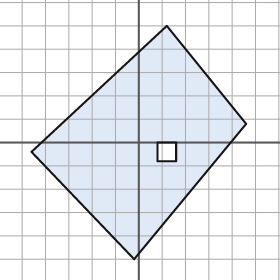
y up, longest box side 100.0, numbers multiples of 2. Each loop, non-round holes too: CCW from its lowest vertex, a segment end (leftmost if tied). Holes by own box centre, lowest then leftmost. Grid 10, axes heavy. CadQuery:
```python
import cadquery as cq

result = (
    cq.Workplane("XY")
    .moveTo(-2.0, -50.0)
    .lineTo(46.0, 8.0)
    .lineTo(12.0, 50.0)
    .lineTo(-46.0, -4.0)
    .close()
    .moveTo(8.0, -8.0)
    .lineTo(16.0, -8.0)
    .lineTo(16.0, 0.0)
    .lineTo(8.0, 0.0)
    .close()
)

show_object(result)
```